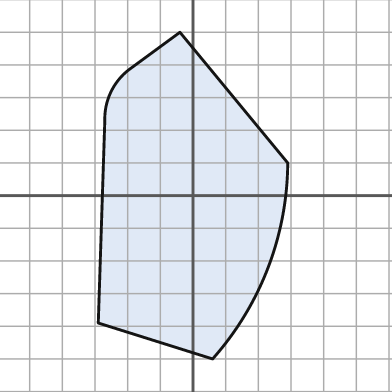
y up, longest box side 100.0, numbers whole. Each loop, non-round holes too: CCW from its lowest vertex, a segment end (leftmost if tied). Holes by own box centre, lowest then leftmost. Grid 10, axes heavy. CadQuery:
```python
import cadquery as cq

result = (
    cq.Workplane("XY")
    .moveTo(6.0, -50.0)
    .threePointArc((23.0, -22.0), (29.0, 10.0))
    .lineTo(-4.0, 50.0)
    .lineTo(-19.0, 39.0)
    .threePointArc((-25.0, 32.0), (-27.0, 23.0))
    .lineTo(-29.0, -39.0)
    .close()
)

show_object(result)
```